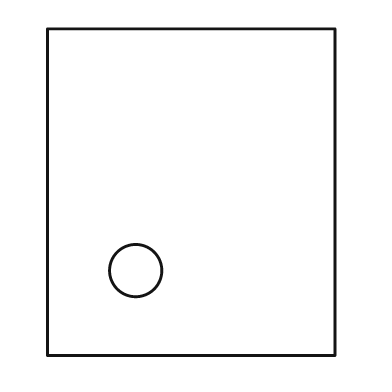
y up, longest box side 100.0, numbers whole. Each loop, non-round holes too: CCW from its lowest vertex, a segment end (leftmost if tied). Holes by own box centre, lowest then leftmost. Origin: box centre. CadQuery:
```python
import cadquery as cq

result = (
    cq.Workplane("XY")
    .moveTo(-44.0, -50.0)
    .lineTo(44.0, -50.0)
    .lineTo(44.0, 50.0)
    .lineTo(-44.0, 50.0)
    .close()
    .moveTo(-17.0, -24.0)
    .circle(8.0)
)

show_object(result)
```